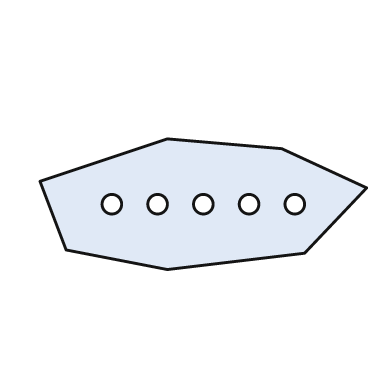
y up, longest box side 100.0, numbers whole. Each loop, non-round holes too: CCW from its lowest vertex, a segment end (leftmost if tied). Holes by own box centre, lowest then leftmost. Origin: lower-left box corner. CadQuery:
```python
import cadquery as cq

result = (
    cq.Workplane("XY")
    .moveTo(39.0, 0.0)
    .lineTo(81.0, 5.0)
    .lineTo(100.0, 25.0)
    .lineTo(74.0, 37.0)
    .lineTo(39.0, 40.0)
    .lineTo(0.0, 27.0)
    .lineTo(8.0, 6.0)
    .close()
    .moveTo(22.0, 20.0)
    .circle(3.0)
    .moveTo(36.0, 20.0)
    .circle(3.0)
    .moveTo(50.0, 20.0)
    .circle(3.0)
    .moveTo(64.0, 20.0)
    .circle(3.0)
    .moveTo(78.0, 20.0)
    .circle(3.0)
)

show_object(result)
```